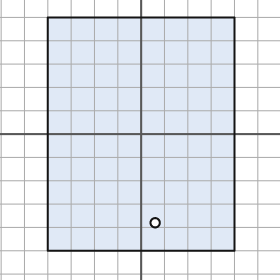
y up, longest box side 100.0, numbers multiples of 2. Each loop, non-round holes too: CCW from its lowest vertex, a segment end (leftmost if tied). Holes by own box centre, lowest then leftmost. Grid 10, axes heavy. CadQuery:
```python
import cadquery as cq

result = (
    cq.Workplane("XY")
    .moveTo(-40.0, -50.0)
    .lineTo(40.0, -50.0)
    .lineTo(40.0, 50.0)
    .lineTo(-40.0, 50.0)
    .close()
    .moveTo(6.0, -38.0)
    .circle(2.0)
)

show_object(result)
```